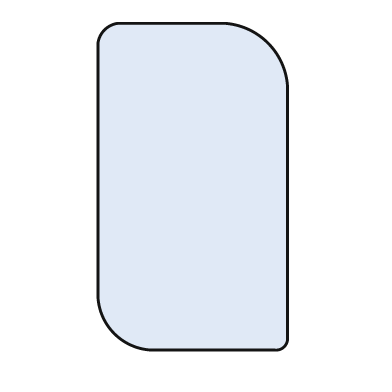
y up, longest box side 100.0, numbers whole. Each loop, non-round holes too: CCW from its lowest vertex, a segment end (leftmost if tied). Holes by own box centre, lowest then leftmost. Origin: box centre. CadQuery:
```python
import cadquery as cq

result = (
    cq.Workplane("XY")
    .moveTo(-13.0, -50.0)
    .lineTo(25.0, -50.0)
    .threePointArc((28.0, -49.0), (29.0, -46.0))
    .lineTo(29.0, 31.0)
    .threePointArc((23.0, 44.0), (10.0, 50.0))
    .lineTo(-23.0, 50.0)
    .threePointArc((-27.0, 48.0), (-29.0, 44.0))
    .lineTo(-29.0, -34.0)
    .threePointArc((-24.0, -45.0), (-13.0, -50.0))
    .close()
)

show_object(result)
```